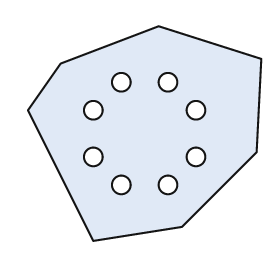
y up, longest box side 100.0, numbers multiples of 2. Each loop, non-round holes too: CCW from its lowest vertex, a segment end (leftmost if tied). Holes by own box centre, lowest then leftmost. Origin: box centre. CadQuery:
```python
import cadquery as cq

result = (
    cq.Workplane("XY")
    .moveTo(-22.0, -46.0)
    .lineTo(16.0, -40.0)
    .lineTo(48.0, -8.0)
    .lineTo(50.0, 32.0)
    .lineTo(6.0, 46.0)
    .lineTo(-36.0, 30.0)
    .lineTo(-50.0, 10.0)
    .close()
    .moveTo(-10.0, -22.0)
    .circle(4.0)
    .moveTo(10.0, -22.0)
    .circle(4.0)
    .moveTo(-22.0, -10.0)
    .circle(4.0)
    .moveTo(22.0, -10.0)
    .circle(4.0)
    .moveTo(-22.0, 10.0)
    .circle(4.0)
    .moveTo(22.0, 10.0)
    .circle(4.0)
    .moveTo(-10.0, 22.0)
    .circle(4.0)
    .moveTo(10.0, 22.0)
    .circle(4.0)
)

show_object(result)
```